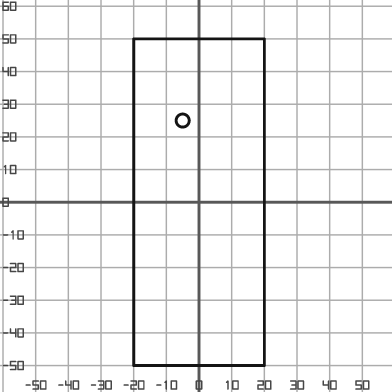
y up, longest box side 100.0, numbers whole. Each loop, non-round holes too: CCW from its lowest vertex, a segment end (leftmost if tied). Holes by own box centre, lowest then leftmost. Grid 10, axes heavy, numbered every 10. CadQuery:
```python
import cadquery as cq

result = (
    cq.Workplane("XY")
    .moveTo(-20.0, -50.0)
    .lineTo(20.0, -50.0)
    .lineTo(20.0, 50.0)
    .lineTo(-20.0, 50.0)
    .close()
    .moveTo(-5.0, 25.0)
    .circle(2.0)
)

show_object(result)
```